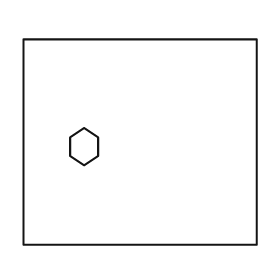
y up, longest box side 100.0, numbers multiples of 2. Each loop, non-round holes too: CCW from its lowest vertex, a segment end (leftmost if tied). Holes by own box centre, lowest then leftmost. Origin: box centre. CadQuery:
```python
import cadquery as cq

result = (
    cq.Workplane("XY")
    .moveTo(-50.0, -44.0)
    .lineTo(50.0, -44.0)
    .lineTo(50.0, 44.0)
    .lineTo(-50.0, 44.0)
    .close()
    .moveTo(-24.0, -10.0)
    .lineTo(-18.0, -6.0)
    .lineTo(-18.0, 2.0)
    .lineTo(-24.0, 6.0)
    .lineTo(-30.0, 2.0)
    .lineTo(-30.0, -6.0)
    .close()
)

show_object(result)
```